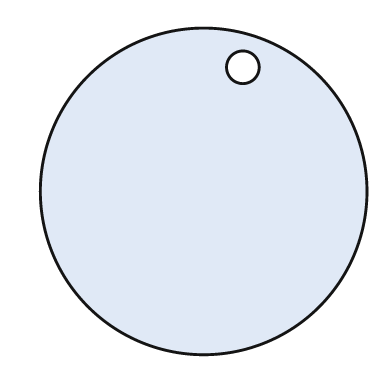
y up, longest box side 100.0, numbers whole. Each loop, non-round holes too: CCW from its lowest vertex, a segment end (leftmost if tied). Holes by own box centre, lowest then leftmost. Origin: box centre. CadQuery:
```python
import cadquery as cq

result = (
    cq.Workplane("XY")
    .moveTo(0.0, 0.0)
    .circle(50.0)
    .moveTo(12.0, 38.0)
    .circle(5.0)
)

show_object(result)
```